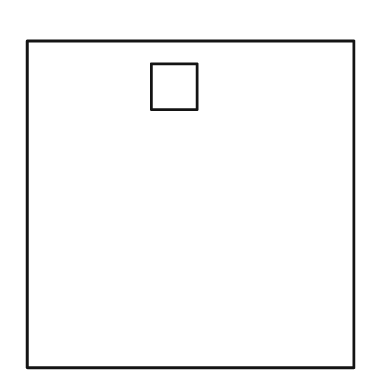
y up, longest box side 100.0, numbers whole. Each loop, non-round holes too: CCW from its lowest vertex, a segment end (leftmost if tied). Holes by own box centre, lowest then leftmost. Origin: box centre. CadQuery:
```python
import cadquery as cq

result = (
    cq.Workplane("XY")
    .moveTo(-50.0, -50.0)
    .lineTo(50.0, -50.0)
    .lineTo(50.0, 50.0)
    .lineTo(-50.0, 50.0)
    .close()
    .moveTo(-12.0, 29.0)
    .lineTo(2.0, 29.0)
    .lineTo(2.0, 43.0)
    .lineTo(-12.0, 43.0)
    .close()
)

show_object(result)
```